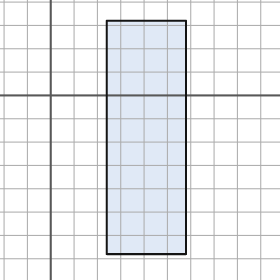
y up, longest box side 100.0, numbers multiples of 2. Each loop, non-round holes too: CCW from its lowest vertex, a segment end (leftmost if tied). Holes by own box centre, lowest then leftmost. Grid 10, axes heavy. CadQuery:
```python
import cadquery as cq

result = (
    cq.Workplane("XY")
    .moveTo(24.0, -68.0)
    .lineTo(58.0, -68.0)
    .lineTo(58.0, 32.0)
    .lineTo(24.0, 32.0)
    .close()
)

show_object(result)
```